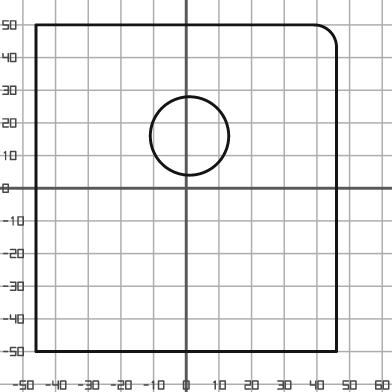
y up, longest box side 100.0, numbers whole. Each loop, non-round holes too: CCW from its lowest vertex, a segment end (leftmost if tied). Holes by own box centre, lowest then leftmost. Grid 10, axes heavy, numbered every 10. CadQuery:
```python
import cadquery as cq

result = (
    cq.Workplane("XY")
    .moveTo(-46.0, -50.0)
    .lineTo(46.0, -50.0)
    .lineTo(46.0, 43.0)
    .threePointArc((44.0, 48.0), (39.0, 50.0))
    .lineTo(-46.0, 50.0)
    .close()
    .moveTo(1.0, 16.0)
    .circle(12.0)
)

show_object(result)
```